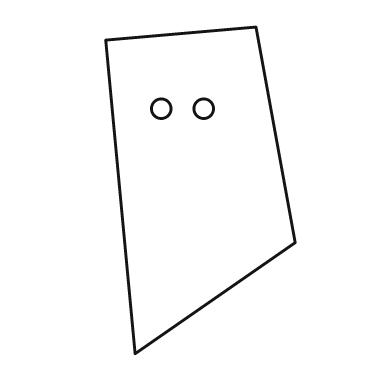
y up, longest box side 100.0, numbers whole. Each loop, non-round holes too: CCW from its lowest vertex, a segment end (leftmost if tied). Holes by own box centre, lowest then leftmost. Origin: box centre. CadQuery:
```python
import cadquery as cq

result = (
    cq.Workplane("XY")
    .moveTo(-20.0, -50.0)
    .lineTo(29.0, -16.0)
    .lineTo(17.0, 50.0)
    .lineTo(-29.0, 46.0)
    .close()
    .moveTo(-12.0, 25.0)
    .circle(3.0)
    .moveTo(1.0, 25.0)
    .circle(3.0)
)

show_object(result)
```